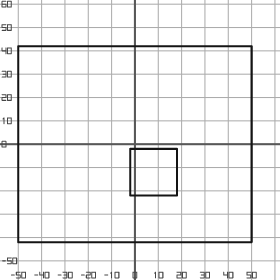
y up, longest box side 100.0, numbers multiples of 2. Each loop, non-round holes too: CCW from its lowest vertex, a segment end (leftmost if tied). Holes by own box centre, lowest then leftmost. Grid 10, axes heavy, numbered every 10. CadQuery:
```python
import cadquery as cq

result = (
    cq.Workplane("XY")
    .moveTo(-50.0, -42.0)
    .lineTo(50.0, -42.0)
    .lineTo(50.0, 42.0)
    .lineTo(-50.0, 42.0)
    .close()
    .moveTo(-2.0, -22.0)
    .lineTo(18.0, -22.0)
    .lineTo(18.0, -2.0)
    .lineTo(-2.0, -2.0)
    .close()
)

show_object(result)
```